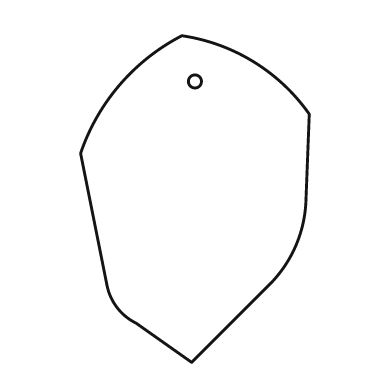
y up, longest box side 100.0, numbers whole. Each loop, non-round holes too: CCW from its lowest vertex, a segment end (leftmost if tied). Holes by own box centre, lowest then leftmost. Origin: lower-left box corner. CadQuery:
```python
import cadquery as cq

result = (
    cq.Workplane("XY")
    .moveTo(34.0, 0.0)
    .lineTo(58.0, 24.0)
    .threePointArc((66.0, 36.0), (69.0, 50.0))
    .lineTo(70.0, 76.0)
    .threePointArc((53.0, 92.0), (31.0, 100.0))
    .threePointArc((12.0, 85.0), (0.0, 64.0))
    .lineTo(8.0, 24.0)
    .threePointArc((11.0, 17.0), (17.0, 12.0))
    .close()
    .moveTo(35.0, 86.0)
    .circle(2.0)
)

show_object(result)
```